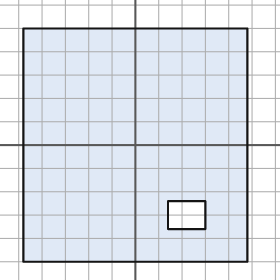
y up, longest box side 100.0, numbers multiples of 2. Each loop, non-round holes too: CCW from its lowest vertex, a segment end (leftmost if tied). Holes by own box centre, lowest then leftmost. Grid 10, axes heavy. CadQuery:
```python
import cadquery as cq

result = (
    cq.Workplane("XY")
    .moveTo(-48.0, -50.0)
    .lineTo(48.0, -50.0)
    .lineTo(48.0, 50.0)
    .lineTo(-48.0, 50.0)
    .close()
    .moveTo(14.0, -36.0)
    .lineTo(30.0, -36.0)
    .lineTo(30.0, -24.0)
    .lineTo(14.0, -24.0)
    .close()
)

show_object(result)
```